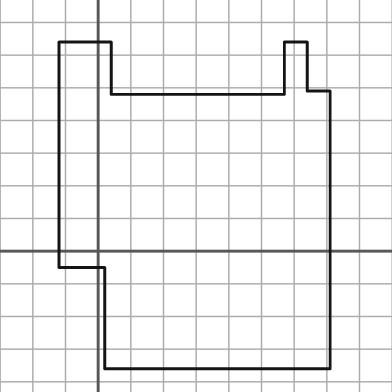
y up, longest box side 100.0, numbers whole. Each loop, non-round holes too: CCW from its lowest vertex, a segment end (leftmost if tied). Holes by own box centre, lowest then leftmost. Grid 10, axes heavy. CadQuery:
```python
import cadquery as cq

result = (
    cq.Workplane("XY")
    .moveTo(2.0, -36.0)
    .lineTo(71.0, -36.0)
    .lineTo(71.0, 49.0)
    .lineTo(64.0, 49.0)
    .lineTo(64.0, 64.0)
    .lineTo(57.0, 64.0)
    .lineTo(57.0, 48.0)
    .lineTo(4.0, 48.0)
    .lineTo(4.0, 64.0)
    .lineTo(-12.0, 64.0)
    .lineTo(-12.0, -5.0)
    .lineTo(2.0, -5.0)
    .close()
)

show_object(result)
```